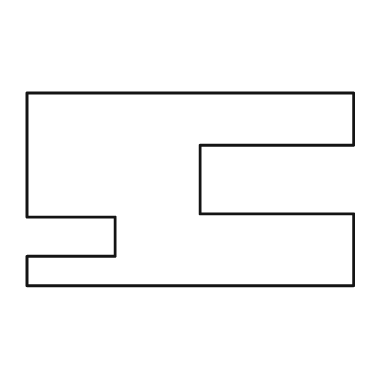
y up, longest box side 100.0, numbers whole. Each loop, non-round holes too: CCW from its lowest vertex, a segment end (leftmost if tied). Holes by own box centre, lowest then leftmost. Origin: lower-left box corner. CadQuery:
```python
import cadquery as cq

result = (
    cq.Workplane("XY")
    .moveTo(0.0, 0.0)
    .lineTo(100.0, 0.0)
    .lineTo(100.0, 22.0)
    .lineTo(53.0, 22.0)
    .lineTo(53.0, 43.0)
    .lineTo(100.0, 43.0)
    .lineTo(100.0, 59.0)
    .lineTo(0.0, 59.0)
    .lineTo(0.0, 21.0)
    .lineTo(27.0, 21.0)
    .lineTo(27.0, 9.0)
    .lineTo(0.0, 9.0)
    .close()
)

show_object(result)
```